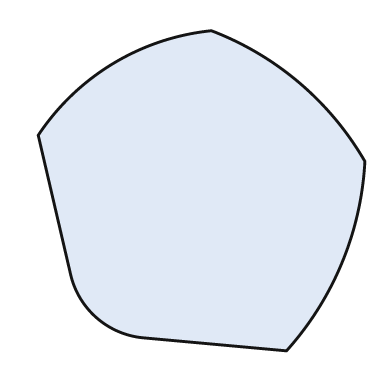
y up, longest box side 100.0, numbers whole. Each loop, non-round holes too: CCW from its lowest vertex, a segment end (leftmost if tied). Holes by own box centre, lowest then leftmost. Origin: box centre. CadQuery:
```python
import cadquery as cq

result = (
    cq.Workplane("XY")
    .moveTo(26.0, -49.0)
    .threePointArc((43.0, -22.0), (50.0, 9.0))
    .threePointArc((30.0, 33.0), (3.0, 49.0))
    .threePointArc((-27.0, 39.0), (-50.0, 17.0))
    .lineTo(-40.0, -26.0)
    .threePointArc((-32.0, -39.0), (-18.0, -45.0))
    .close()
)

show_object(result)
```